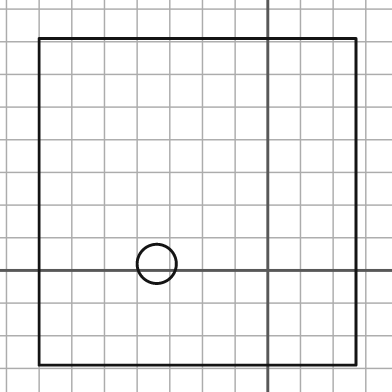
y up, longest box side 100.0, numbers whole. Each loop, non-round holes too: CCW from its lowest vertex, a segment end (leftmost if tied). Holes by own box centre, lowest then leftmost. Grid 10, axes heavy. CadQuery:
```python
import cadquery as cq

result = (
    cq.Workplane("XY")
    .moveTo(-70.0, -29.0)
    .lineTo(27.0, -29.0)
    .lineTo(27.0, 71.0)
    .lineTo(-70.0, 71.0)
    .close()
    .moveTo(-34.0, 2.0)
    .circle(6.0)
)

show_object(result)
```